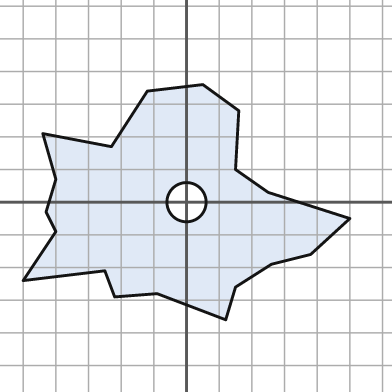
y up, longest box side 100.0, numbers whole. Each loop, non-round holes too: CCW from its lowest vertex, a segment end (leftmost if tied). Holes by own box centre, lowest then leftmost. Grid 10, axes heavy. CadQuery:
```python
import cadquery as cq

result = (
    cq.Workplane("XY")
    .moveTo(12.0, -36.0)
    .lineTo(15.0, -26.0)
    .lineTo(26.0, -19.0)
    .lineTo(38.0, -16.0)
    .lineTo(50.0, -5.0)
    .lineTo(25.0, 3.0)
    .lineTo(15.0, 10.0)
    .lineTo(16.0, 28.0)
    .lineTo(5.0, 36.0)
    .lineTo(-12.0, 34.0)
    .lineTo(-23.0, 17.0)
    .lineTo(-44.0, 21.0)
    .lineTo(-40.0, 7.0)
    .lineTo(-43.0, -3.0)
    .lineTo(-40.0, -9.0)
    .lineTo(-50.0, -24.0)
    .lineTo(-25.0, -21.0)
    .lineTo(-22.0, -29.0)
    .lineTo(-9.0, -28.0)
    .close()
    .moveTo(0.0, 0.0)
    .circle(6.0)
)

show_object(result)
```